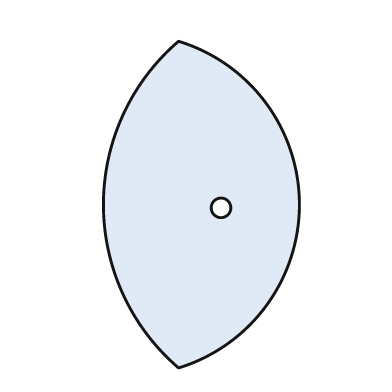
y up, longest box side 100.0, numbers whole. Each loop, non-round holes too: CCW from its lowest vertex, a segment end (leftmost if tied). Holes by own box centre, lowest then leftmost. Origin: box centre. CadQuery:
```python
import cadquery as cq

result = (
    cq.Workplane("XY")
    .moveTo(-7.0, -50.0)
    .threePointArc((30.0, 0.0), (-7.0, 50.0))
    .threePointArc((-30.0, 0.0), (-7.0, -50.0))
    .close()
    .moveTo(6.0, -1.0)
    .circle(3.0)
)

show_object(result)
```